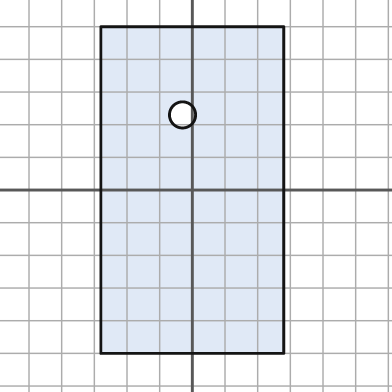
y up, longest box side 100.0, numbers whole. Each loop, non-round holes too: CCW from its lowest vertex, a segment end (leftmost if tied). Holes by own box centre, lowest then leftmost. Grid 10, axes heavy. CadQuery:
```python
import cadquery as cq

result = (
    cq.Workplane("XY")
    .moveTo(-28.0, -50.0)
    .lineTo(28.0, -50.0)
    .lineTo(28.0, 50.0)
    .lineTo(-28.0, 50.0)
    .close()
    .moveTo(-3.0, 23.0)
    .circle(4.0)
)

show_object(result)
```